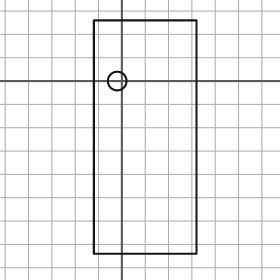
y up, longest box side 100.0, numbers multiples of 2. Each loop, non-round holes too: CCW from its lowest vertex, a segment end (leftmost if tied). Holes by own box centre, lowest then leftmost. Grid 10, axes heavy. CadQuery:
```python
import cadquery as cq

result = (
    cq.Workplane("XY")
    .moveTo(-12.0, -74.0)
    .lineTo(32.0, -74.0)
    .lineTo(32.0, 26.0)
    .lineTo(-12.0, 26.0)
    .close()
    .moveTo(-2.0, 0.0)
    .circle(4.0)
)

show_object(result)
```